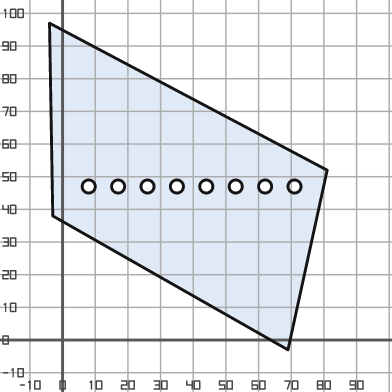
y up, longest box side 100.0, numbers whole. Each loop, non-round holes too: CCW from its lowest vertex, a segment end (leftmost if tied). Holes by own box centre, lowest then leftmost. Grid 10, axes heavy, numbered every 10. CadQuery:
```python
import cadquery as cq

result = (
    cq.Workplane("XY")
    .moveTo(69.0, -3.0)
    .lineTo(81.0, 52.0)
    .lineTo(-4.0, 97.0)
    .lineTo(-3.0, 38.0)
    .close()
    .moveTo(8.0, 47.0)
    .circle(2.0)
    .moveTo(17.0, 47.0)
    .circle(2.0)
    .moveTo(26.0, 47.0)
    .circle(2.0)
    .moveTo(35.0, 47.0)
    .circle(2.0)
    .moveTo(44.0, 47.0)
    .circle(2.0)
    .moveTo(53.0, 47.0)
    .circle(2.0)
    .moveTo(62.0, 47.0)
    .circle(2.0)
    .moveTo(71.0, 47.0)
    .circle(2.0)
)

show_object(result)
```